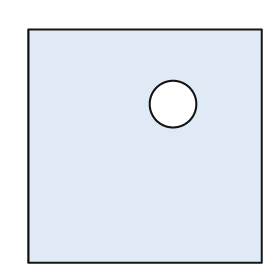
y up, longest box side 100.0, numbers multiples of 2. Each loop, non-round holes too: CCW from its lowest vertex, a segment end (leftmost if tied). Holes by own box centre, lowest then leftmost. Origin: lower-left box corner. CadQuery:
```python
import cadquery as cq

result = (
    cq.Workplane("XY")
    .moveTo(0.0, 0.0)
    .lineTo(100.0, 0.0)
    .lineTo(100.0, 100.0)
    .lineTo(0.0, 100.0)
    .close()
    .moveTo(62.0, 68.0)
    .circle(10.0)
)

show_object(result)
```